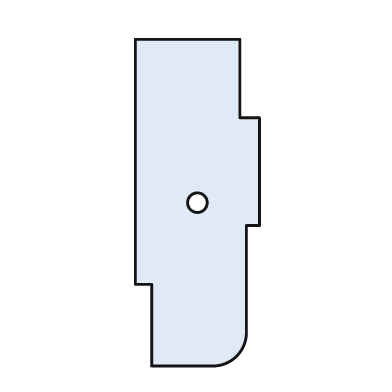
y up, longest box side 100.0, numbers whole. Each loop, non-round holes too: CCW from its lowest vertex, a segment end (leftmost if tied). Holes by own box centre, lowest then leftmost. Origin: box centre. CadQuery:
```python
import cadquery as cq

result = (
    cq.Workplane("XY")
    .moveTo(-14.0, -50.0)
    .lineTo(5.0, -50.0)
    .threePointArc((12.0, -47.0), (15.0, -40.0))
    .lineTo(15.0, -7.0)
    .lineTo(19.0, -7.0)
    .lineTo(19.0, 26.0)
    .lineTo(13.0, 26.0)
    .lineTo(13.0, 50.0)
    .lineTo(-19.0, 50.0)
    .lineTo(-19.0, -25.0)
    .lineTo(-14.0, -25.0)
    .close()
    .moveTo(0.0, 0.0)
    .circle(3.0)
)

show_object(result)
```